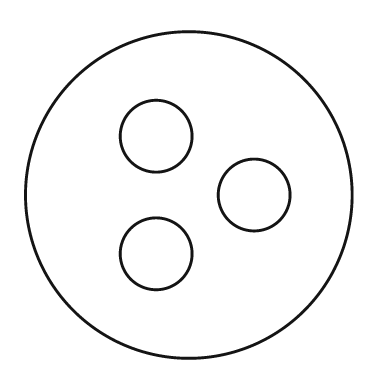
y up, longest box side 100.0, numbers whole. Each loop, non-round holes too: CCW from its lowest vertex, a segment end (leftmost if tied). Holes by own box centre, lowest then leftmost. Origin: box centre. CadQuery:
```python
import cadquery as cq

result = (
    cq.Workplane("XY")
    .moveTo(0.0, 0.0)
    .circle(50.0)
    .moveTo(-10.0, -18.0)
    .circle(11.0)
    .moveTo(20.0, 0.0)
    .circle(11.0)
    .moveTo(-10.0, 18.0)
    .circle(11.0)
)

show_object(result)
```